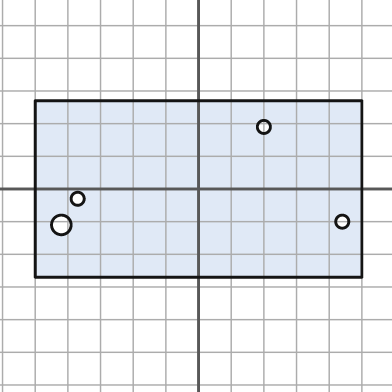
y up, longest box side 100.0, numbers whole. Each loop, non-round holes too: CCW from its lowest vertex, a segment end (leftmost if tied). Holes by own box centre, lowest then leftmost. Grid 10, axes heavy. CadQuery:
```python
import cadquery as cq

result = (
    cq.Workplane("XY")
    .moveTo(-50.0, -27.0)
    .lineTo(50.0, -27.0)
    .lineTo(50.0, 27.0)
    .lineTo(-50.0, 27.0)
    .close()
    .moveTo(-42.0, -11.0)
    .circle(3.0)
    .moveTo(44.0, -10.0)
    .circle(2.0)
    .moveTo(-37.0, -3.0)
    .circle(2.0)
    .moveTo(20.0, 19.0)
    .circle(2.0)
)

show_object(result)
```